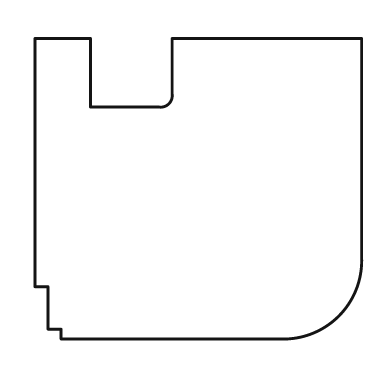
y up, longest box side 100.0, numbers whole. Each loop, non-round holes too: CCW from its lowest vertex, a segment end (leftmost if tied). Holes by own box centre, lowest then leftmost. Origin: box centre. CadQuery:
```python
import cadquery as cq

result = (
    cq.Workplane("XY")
    .moveTo(-42.0, -46.0)
    .lineTo(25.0, -46.0)
    .threePointArc((43.0, -39.0), (50.0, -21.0))
    .lineTo(50.0, 46.0)
    .lineTo(-8.0, 46.0)
    .lineTo(-8.0, 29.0)
    .threePointArc((-9.0, 26.0), (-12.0, 25.0))
    .lineTo(-33.0, 25.0)
    .lineTo(-33.0, 46.0)
    .lineTo(-50.0, 46.0)
    .lineTo(-50.0, -30.0)
    .lineTo(-46.0, -30.0)
    .lineTo(-46.0, -43.0)
    .lineTo(-42.0, -43.0)
    .close()
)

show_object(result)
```